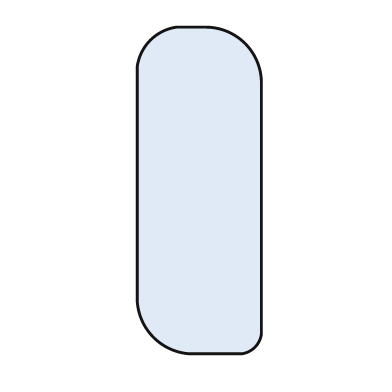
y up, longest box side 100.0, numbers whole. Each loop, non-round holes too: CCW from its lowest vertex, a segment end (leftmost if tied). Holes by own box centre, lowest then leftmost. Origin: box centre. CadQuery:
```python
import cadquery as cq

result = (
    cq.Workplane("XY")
    .moveTo(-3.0, -50.0)
    .lineTo(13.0, -50.0)
    .threePointArc((17.0, -48.0), (19.0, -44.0))
    .lineTo(19.0, 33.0)
    .threePointArc((14.0, 45.0), (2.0, 50.0))
    .lineTo(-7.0, 50.0)
    .threePointArc((-15.0, 46.0), (-19.0, 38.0))
    .lineTo(-19.0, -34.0)
    .threePointArc((-14.0, -45.0), (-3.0, -50.0))
    .close()
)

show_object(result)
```